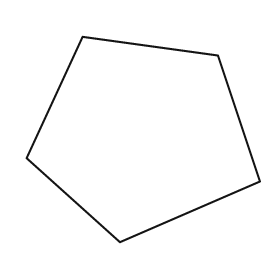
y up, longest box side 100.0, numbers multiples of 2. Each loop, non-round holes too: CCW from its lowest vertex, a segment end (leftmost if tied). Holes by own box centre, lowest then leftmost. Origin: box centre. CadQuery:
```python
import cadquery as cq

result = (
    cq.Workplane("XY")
    .moveTo(-10.0, -44.0)
    .lineTo(50.0, -18.0)
    .lineTo(32.0, 36.0)
    .lineTo(-26.0, 44.0)
    .lineTo(-50.0, -8.0)
    .close()
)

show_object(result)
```